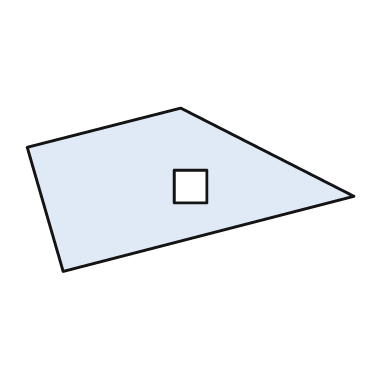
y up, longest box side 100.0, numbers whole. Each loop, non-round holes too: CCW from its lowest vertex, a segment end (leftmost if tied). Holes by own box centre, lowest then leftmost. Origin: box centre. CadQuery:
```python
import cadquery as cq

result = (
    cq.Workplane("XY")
    .moveTo(-39.0, -25.0)
    .lineTo(50.0, -2.0)
    .lineTo(-3.0, 25.0)
    .lineTo(-50.0, 13.0)
    .close()
    .moveTo(-5.0, -4.0)
    .lineTo(5.0, -4.0)
    .lineTo(5.0, 6.0)
    .lineTo(-5.0, 6.0)
    .close()
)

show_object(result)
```